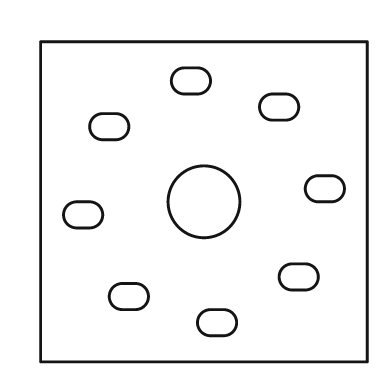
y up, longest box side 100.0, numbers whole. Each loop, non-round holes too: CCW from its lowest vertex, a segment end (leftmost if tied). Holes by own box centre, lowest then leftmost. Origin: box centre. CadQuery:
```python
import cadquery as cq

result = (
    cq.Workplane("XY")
    .moveTo(-50.0, -49.0)
    .lineTo(50.0, -49.0)
    .lineTo(50.0, 49.0)
    .lineTo(-50.0, 49.0)
    .close()
    .moveTo(2.0, -41.0)
    .lineTo(6.0, -41.0)
    .threePointArc((10.0, -37.0), (6.0, -33.0))
    .lineTo(2.0, -33.0)
    .threePointArc((-2.0, -37.0), (2.0, -41.0))
    .close()
    .moveTo(-25.0, -33.0)
    .lineTo(-21.0, -33.0)
    .threePointArc((-17.0, -29.0), (-21.0, -25.0))
    .lineTo(-25.0, -25.0)
    .threePointArc((-29.0, -29.0), (-25.0, -33.0))
    .close()
    .moveTo(27.0, -27.0)
    .lineTo(31.0, -27.0)
    .threePointArc((35.0, -23.0), (31.0, -19.0))
    .lineTo(27.0, -19.0)
    .threePointArc((23.0, -23.0), (27.0, -27.0))
    .close()
    .moveTo(-39.0, -8.0)
    .lineTo(-35.0, -8.0)
    .threePointArc((-31.0, -4.0), (-35.0, 0.0))
    .lineTo(-39.0, 0.0)
    .threePointArc((-43.0, -4.0), (-39.0, -8.0))
    .close()
    .moveTo(0.0, 0.0)
    .circle(11.0)
    .moveTo(35.0, 0.0)
    .lineTo(39.0, 0.0)
    .threePointArc((43.0, 4.0), (39.0, 8.0))
    .lineTo(35.0, 8.0)
    .threePointArc((31.0, 4.0), (35.0, 0.0))
    .close()
    .moveTo(-31.0, 19.0)
    .lineTo(-27.0, 19.0)
    .threePointArc((-23.0, 23.0), (-27.0, 27.0))
    .lineTo(-31.0, 27.0)
    .threePointArc((-35.0, 23.0), (-31.0, 19.0))
    .close()
    .moveTo(21.0, 25.0)
    .lineTo(25.0, 25.0)
    .threePointArc((29.0, 29.0), (25.0, 33.0))
    .lineTo(21.0, 33.0)
    .threePointArc((17.0, 29.0), (21.0, 25.0))
    .close()
    .moveTo(-6.0, 33.0)
    .lineTo(-2.0, 33.0)
    .threePointArc((2.0, 37.0), (-2.0, 41.0))
    .lineTo(-6.0, 41.0)
    .threePointArc((-10.0, 37.0), (-6.0, 33.0))
    .close()
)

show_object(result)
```